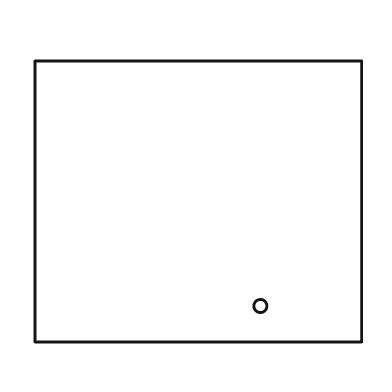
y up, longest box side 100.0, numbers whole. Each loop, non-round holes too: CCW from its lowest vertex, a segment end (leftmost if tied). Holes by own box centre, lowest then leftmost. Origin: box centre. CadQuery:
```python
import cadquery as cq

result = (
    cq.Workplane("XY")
    .moveTo(-50.0, -43.0)
    .lineTo(50.0, -43.0)
    .lineTo(50.0, 43.0)
    .lineTo(-50.0, 43.0)
    .close()
    .moveTo(19.0, -32.0)
    .circle(2.0)
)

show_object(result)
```